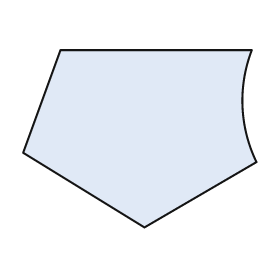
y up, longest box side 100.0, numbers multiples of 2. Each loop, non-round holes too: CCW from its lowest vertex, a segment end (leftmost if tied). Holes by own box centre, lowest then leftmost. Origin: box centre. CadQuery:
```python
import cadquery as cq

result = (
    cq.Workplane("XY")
    .moveTo(2.0, -38.0)
    .lineTo(50.0, -10.0)
    .threePointArc((44.0, 14.0), (48.0, 38.0))
    .lineTo(-34.0, 38.0)
    .lineTo(-50.0, -6.0)
    .close()
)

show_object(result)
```